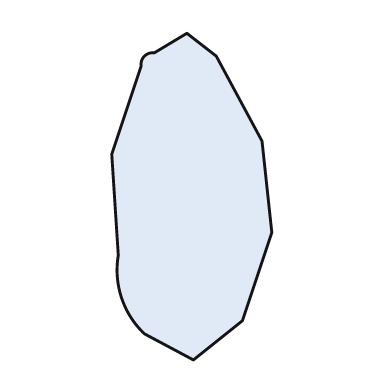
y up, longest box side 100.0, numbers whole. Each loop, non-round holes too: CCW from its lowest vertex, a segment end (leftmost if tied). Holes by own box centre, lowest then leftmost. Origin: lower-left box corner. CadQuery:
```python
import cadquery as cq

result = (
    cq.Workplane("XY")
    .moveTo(25.0, 0.0)
    .lineTo(40.0, 12.0)
    .lineTo(49.0, 39.0)
    .lineTo(46.0, 67.0)
    .lineTo(32.0, 93.0)
    .lineTo(23.0, 100.0)
    .lineTo(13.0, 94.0)
    .threePointArc((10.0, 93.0), (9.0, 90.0))
    .lineTo(0.0, 63.0)
    .lineTo(2.0, 32.0)
    .threePointArc((3.0, 19.0), (10.0, 8.0))
    .close()
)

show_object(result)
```